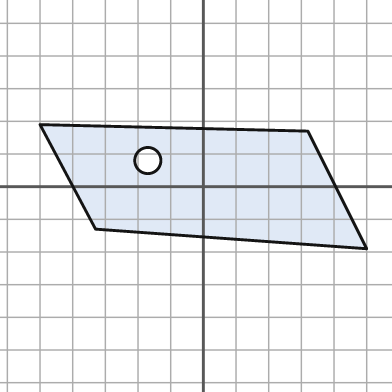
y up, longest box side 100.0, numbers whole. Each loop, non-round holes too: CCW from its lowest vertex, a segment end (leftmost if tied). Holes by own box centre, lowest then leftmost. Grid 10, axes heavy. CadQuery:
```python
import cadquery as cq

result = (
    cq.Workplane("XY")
    .moveTo(50.0, -19.0)
    .lineTo(32.0, 17.0)
    .lineTo(-50.0, 19.0)
    .lineTo(-33.0, -13.0)
    .close()
    .moveTo(-17.0, 8.0)
    .circle(4.0)
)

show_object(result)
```